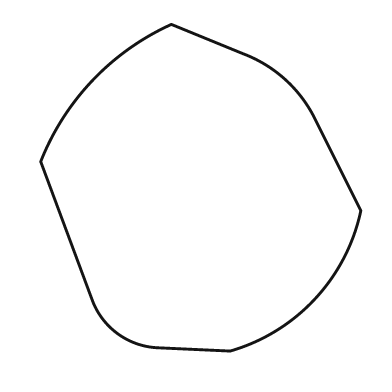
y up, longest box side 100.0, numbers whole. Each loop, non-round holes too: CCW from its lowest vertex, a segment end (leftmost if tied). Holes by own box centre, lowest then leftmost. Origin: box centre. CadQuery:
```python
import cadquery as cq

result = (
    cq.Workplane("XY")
    .moveTo(9.0, -50.0)
    .threePointArc((35.0, -34.0), (49.0, -7.0))
    .lineTo(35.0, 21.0)
    .threePointArc((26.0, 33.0), (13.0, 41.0))
    .lineTo(-9.0, 50.0)
    .threePointArc((-33.0, 33.0), (-49.0, 8.0))
    .lineTo(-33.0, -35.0)
    .threePointArc((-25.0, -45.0), (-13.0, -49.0))
    .close()
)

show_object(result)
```